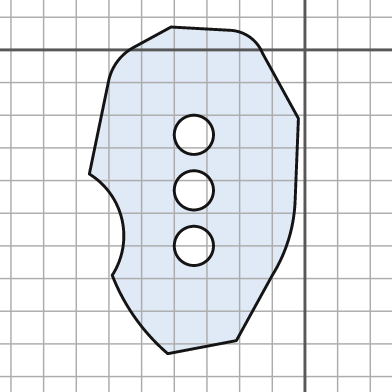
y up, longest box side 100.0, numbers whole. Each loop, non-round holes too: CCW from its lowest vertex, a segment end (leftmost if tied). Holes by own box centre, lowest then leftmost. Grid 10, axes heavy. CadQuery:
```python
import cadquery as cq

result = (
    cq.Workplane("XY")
    .moveTo(-42.0, -93.0)
    .lineTo(-21.0, -89.0)
    .lineTo(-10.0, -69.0)
    .threePointArc((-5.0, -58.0), (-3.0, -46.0))
    .lineTo(-2.0, -21.0)
    .lineTo(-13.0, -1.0)
    .threePointArc((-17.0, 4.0), (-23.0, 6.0))
    .lineTo(-41.0, 7.0)
    .lineTo(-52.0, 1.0)
    .threePointArc((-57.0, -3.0), (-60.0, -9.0))
    .lineTo(-66.0, -38.0)
    .threePointArc((-56.0, -52.0), (-59.0, -69.0))
    .threePointArc((-52.0, -82.0), (-42.0, -93.0))
    .close()
    .moveTo(-34.0, -60.0)
    .circle(6.0)
    .moveTo(-34.0, -43.0)
    .circle(6.0)
    .moveTo(-34.0, -26.0)
    .circle(6.0)
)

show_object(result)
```